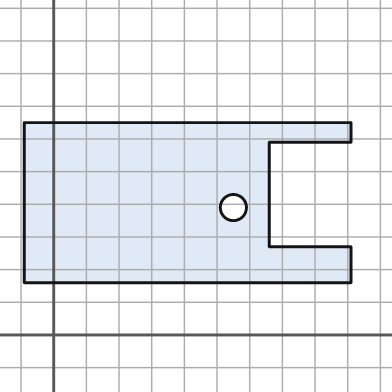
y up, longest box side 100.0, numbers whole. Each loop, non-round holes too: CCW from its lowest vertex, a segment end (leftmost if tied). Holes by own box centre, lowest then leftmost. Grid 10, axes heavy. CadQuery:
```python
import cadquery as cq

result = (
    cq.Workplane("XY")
    .moveTo(-9.0, 16.0)
    .lineTo(91.0, 16.0)
    .lineTo(91.0, 27.0)
    .lineTo(66.0, 27.0)
    .lineTo(66.0, 59.0)
    .lineTo(91.0, 59.0)
    .lineTo(91.0, 65.0)
    .lineTo(-9.0, 65.0)
    .close()
    .moveTo(55.0, 39.0)
    .circle(4.0)
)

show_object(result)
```